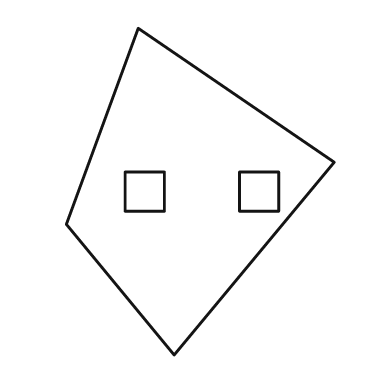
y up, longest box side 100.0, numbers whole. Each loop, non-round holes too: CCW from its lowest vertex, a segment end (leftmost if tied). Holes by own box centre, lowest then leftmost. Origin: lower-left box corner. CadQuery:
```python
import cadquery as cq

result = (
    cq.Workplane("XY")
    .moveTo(33.0, 0.0)
    .lineTo(82.0, 59.0)
    .lineTo(22.0, 100.0)
    .lineTo(0.0, 40.0)
    .close()
    .moveTo(18.0, 44.0)
    .lineTo(30.0, 44.0)
    .lineTo(30.0, 56.0)
    .lineTo(18.0, 56.0)
    .close()
    .moveTo(53.0, 44.0)
    .lineTo(65.0, 44.0)
    .lineTo(65.0, 56.0)
    .lineTo(53.0, 56.0)
    .close()
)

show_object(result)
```